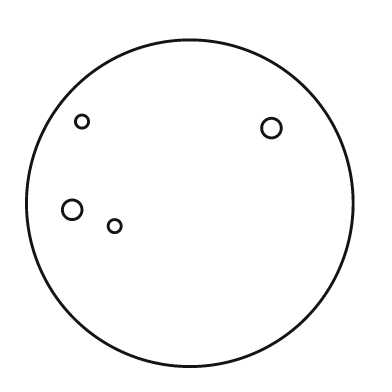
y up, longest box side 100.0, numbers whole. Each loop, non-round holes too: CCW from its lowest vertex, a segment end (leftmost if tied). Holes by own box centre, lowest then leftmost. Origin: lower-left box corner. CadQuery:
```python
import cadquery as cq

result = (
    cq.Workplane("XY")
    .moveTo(50.0, 50.0)
    .circle(50.0)
    .moveTo(27.0, 43.0)
    .circle(2.0)
    .moveTo(14.0, 48.0)
    .circle(3.0)
    .moveTo(75.0, 73.0)
    .circle(3.0)
    .moveTo(17.0, 75.0)
    .circle(2.0)
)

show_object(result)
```